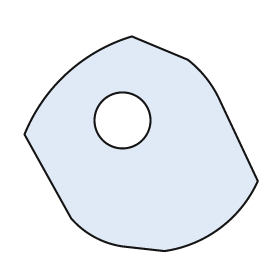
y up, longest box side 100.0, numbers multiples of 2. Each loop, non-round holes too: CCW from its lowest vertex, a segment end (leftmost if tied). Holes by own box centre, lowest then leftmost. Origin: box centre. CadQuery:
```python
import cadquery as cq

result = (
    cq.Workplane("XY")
    .moveTo(10.0, -46.0)
    .threePointArc((34.0, -36.0), (50.0, -16.0))
    .lineTo(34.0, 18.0)
    .threePointArc((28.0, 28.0), (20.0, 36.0))
    .lineTo(-4.0, 46.0)
    .threePointArc((-32.0, 30.0), (-50.0, 4.0))
    .lineTo(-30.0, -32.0)
    .threePointArc((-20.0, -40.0), (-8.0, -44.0))
    .close()
    .moveTo(-8.0, 10.0)
    .circle(12.0)
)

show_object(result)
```